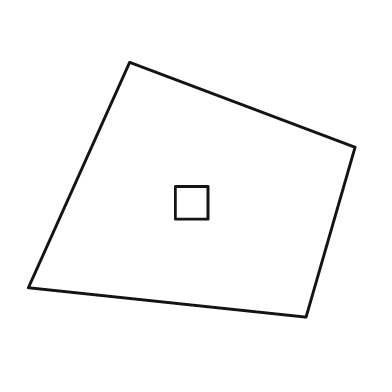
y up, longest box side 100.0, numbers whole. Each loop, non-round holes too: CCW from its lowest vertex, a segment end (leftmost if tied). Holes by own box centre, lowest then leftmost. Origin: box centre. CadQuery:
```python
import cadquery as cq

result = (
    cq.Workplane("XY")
    .moveTo(35.0, -39.0)
    .lineTo(50.0, 13.0)
    .lineTo(-19.0, 39.0)
    .lineTo(-50.0, -30.0)
    .close()
    .moveTo(-5.0, -9.0)
    .lineTo(5.0, -9.0)
    .lineTo(5.0, 1.0)
    .lineTo(-5.0, 1.0)
    .close()
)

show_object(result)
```